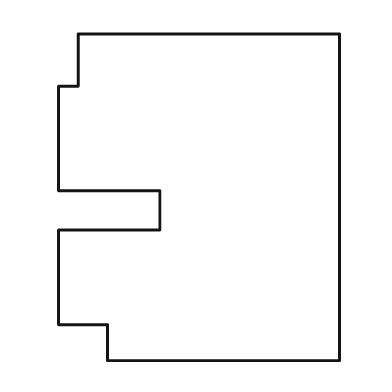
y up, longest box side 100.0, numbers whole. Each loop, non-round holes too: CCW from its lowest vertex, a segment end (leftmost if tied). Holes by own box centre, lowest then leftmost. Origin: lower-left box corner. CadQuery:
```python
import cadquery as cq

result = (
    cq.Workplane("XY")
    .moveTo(15.0, 0.0)
    .lineTo(86.0, 0.0)
    .lineTo(86.0, 100.0)
    .lineTo(6.0, 100.0)
    .lineTo(6.0, 84.0)
    .lineTo(0.0, 84.0)
    .lineTo(0.0, 52.0)
    .lineTo(31.0, 52.0)
    .lineTo(31.0, 40.0)
    .lineTo(0.0, 40.0)
    .lineTo(0.0, 11.0)
    .lineTo(15.0, 11.0)
    .close()
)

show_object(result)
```